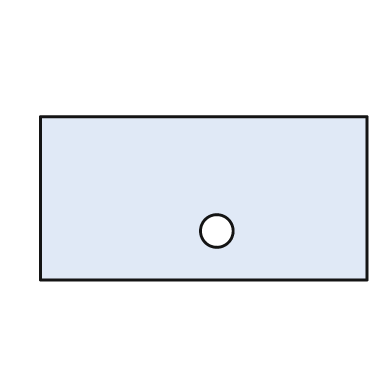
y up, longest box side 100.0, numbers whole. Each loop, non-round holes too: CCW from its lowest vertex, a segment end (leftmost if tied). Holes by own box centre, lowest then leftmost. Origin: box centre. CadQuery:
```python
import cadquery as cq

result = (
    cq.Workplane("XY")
    .moveTo(-50.0, -25.0)
    .lineTo(50.0, -25.0)
    .lineTo(50.0, 25.0)
    .lineTo(-50.0, 25.0)
    .close()
    .moveTo(4.0, -10.0)
    .circle(5.0)
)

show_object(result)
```